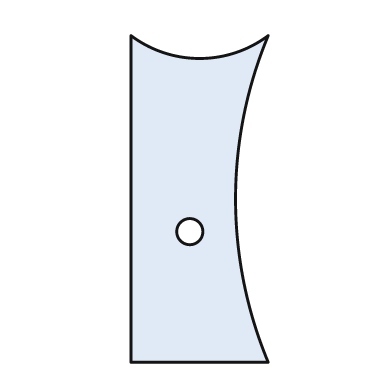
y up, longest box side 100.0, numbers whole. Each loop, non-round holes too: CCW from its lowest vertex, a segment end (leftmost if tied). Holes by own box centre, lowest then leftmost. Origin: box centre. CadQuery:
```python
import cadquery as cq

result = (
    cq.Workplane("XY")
    .moveTo(-21.0, -50.0)
    .lineTo(21.0, -50.0)
    .threePointArc((11.0, 0.0), (21.0, 50.0))
    .threePointArc((0.0, 43.0), (-21.0, 50.0))
    .close()
    .moveTo(-3.0, -10.0)
    .circle(4.0)
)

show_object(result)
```